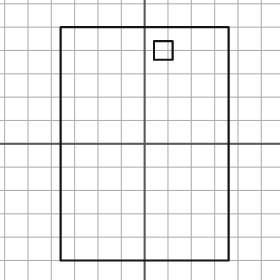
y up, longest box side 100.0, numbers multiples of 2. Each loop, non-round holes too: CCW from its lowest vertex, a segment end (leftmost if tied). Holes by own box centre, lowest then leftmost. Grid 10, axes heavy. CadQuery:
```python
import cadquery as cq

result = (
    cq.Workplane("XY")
    .moveTo(-36.0, -50.0)
    .lineTo(36.0, -50.0)
    .lineTo(36.0, 50.0)
    .lineTo(-36.0, 50.0)
    .close()
    .moveTo(4.0, 36.0)
    .lineTo(12.0, 36.0)
    .lineTo(12.0, 44.0)
    .lineTo(4.0, 44.0)
    .close()
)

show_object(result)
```